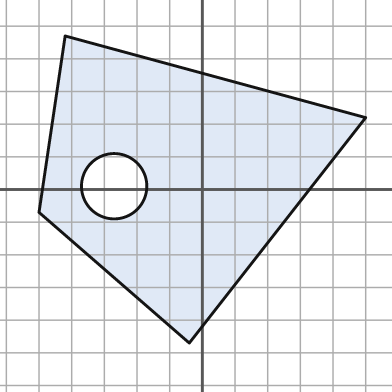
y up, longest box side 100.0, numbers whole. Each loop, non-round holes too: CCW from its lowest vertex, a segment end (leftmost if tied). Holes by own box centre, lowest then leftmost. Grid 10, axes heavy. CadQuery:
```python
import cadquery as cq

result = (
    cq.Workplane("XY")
    .moveTo(-4.0, -47.0)
    .lineTo(50.0, 22.0)
    .lineTo(-42.0, 47.0)
    .lineTo(-50.0, -7.0)
    .close()
    .moveTo(-27.0, 1.0)
    .circle(10.0)
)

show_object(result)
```